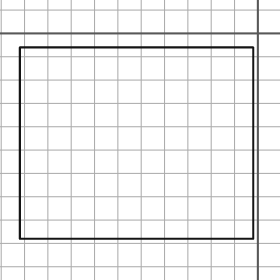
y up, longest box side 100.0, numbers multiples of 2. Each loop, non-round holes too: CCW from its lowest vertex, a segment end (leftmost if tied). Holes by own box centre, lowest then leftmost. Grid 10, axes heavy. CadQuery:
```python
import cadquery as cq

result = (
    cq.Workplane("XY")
    .moveTo(-102.0, -88.0)
    .lineTo(-2.0, -88.0)
    .lineTo(-2.0, -6.0)
    .lineTo(-102.0, -6.0)
    .close()
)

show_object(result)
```